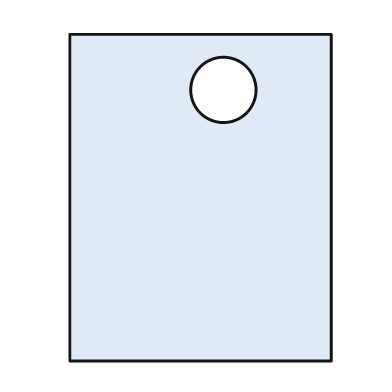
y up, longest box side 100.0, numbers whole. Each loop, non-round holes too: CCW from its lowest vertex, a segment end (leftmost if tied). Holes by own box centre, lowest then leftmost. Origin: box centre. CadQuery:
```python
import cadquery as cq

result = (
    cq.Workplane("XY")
    .moveTo(-40.0, -50.0)
    .lineTo(40.0, -50.0)
    .lineTo(40.0, 50.0)
    .lineTo(-40.0, 50.0)
    .close()
    .moveTo(7.0, 33.0)
    .circle(10.0)
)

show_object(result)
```